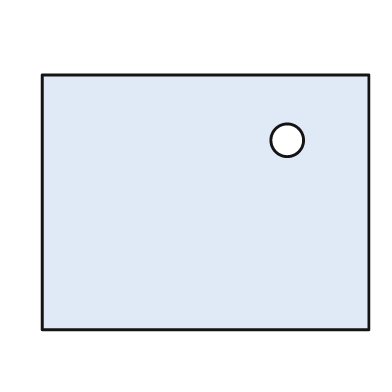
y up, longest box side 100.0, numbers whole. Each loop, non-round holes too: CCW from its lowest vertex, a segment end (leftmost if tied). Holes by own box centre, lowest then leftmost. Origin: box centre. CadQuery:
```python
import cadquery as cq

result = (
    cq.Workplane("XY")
    .moveTo(-50.0, -39.0)
    .lineTo(50.0, -39.0)
    .lineTo(50.0, 39.0)
    .lineTo(-50.0, 39.0)
    .close()
    .moveTo(25.0, 19.0)
    .circle(5.0)
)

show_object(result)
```